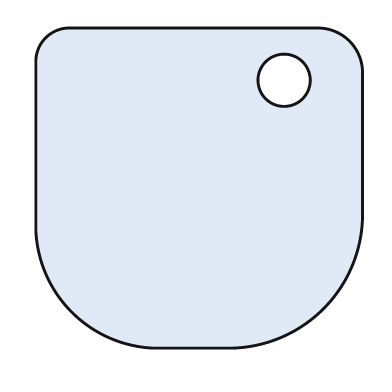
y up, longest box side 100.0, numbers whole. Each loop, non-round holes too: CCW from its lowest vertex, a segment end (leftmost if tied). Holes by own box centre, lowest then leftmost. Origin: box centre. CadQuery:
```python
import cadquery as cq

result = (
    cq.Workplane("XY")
    .moveTo(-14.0, -49.0)
    .lineTo(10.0, -49.0)
    .threePointArc((38.0, -37.0), (50.0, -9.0))
    .lineTo(50.0, 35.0)
    .threePointArc((46.0, 45.0), (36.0, 49.0))
    .lineTo(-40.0, 49.0)
    .threePointArc((-47.0, 46.0), (-50.0, 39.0))
    .lineTo(-50.0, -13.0)
    .threePointArc((-39.0, -38.0), (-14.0, -49.0))
    .close()
    .moveTo(26.0, 33.0)
    .circle(8.0)
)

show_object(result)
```